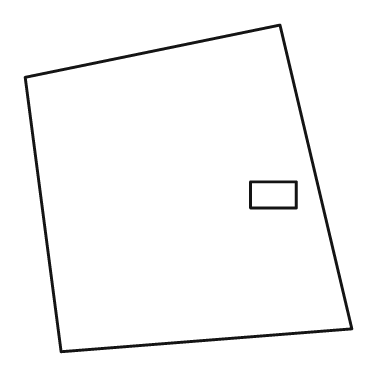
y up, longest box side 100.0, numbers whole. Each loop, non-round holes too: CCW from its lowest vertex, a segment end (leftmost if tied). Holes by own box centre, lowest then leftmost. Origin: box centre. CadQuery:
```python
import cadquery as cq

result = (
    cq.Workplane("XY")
    .moveTo(-39.0, -50.0)
    .lineTo(50.0, -43.0)
    .lineTo(28.0, 50.0)
    .lineTo(-50.0, 34.0)
    .close()
    .moveTo(19.0, -6.0)
    .lineTo(33.0, -6.0)
    .lineTo(33.0, 2.0)
    .lineTo(19.0, 2.0)
    .close()
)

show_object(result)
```